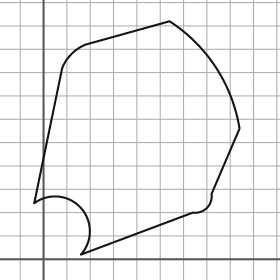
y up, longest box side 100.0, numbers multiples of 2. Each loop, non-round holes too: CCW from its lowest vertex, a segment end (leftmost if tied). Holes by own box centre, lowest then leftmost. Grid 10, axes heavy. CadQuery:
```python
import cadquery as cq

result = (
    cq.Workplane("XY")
    .moveTo(16.0, 2.0)
    .lineTo(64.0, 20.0)
    .threePointArc((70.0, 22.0), (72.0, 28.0))
    .lineTo(84.0, 56.0)
    .threePointArc((74.0, 82.0), (54.0, 102.0))
    .lineTo(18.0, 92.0)
    .threePointArc((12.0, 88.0), (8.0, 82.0))
    .lineTo(-4.0, 24.0)
    .threePointArc((16.0, 22.0), (16.0, 2.0))
    .close()
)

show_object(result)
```